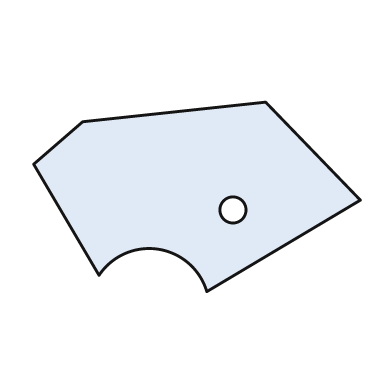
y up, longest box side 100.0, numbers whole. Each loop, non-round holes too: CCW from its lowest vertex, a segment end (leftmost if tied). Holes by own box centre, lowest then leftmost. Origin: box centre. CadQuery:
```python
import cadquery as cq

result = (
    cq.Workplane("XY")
    .moveTo(3.0, -29.0)
    .lineTo(50.0, -1.0)
    .lineTo(21.0, 29.0)
    .lineTo(-35.0, 23.0)
    .lineTo(-50.0, 10.0)
    .lineTo(-30.0, -24.0)
    .threePointArc((-12.0, -16.0), (3.0, -29.0))
    .close()
    .moveTo(11.0, -4.0)
    .circle(4.0)
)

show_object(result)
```